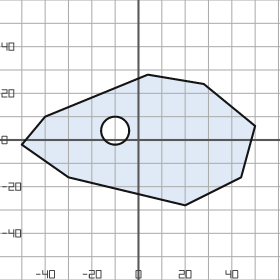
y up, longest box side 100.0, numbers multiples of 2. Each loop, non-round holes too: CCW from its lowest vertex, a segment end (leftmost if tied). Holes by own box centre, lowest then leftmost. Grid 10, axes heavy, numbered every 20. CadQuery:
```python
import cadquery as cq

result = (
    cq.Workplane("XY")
    .moveTo(20.0, -28.0)
    .lineTo(44.0, -16.0)
    .lineTo(50.0, 6.0)
    .lineTo(28.0, 24.0)
    .lineTo(4.0, 28.0)
    .lineTo(-40.0, 10.0)
    .lineTo(-50.0, -2.0)
    .lineTo(-30.0, -16.0)
    .close()
    .moveTo(-10.0, 4.0)
    .circle(6.0)
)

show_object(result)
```